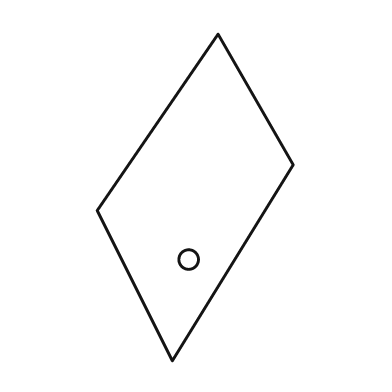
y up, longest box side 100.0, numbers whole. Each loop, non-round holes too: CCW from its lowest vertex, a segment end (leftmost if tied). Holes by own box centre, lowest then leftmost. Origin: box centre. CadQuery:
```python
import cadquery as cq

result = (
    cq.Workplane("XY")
    .moveTo(-7.0, -50.0)
    .lineTo(30.0, 10.0)
    .lineTo(7.0, 50.0)
    .lineTo(-30.0, -4.0)
    .close()
    .moveTo(-2.0, -19.0)
    .circle(3.0)
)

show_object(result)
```